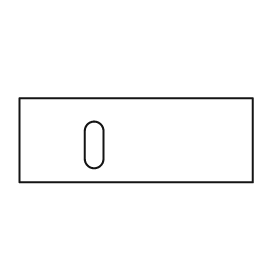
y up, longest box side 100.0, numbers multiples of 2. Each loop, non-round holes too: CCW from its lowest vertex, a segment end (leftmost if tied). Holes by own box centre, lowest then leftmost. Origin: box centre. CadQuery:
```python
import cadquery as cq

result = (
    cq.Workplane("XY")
    .moveTo(-50.0, -18.0)
    .lineTo(50.0, -18.0)
    .lineTo(50.0, 18.0)
    .lineTo(-50.0, 18.0)
    .close()
    .moveTo(-22.0, -8.0)
    .threePointArc((-18.0, -12.0), (-14.0, -8.0))
    .lineTo(-14.0, 4.0)
    .threePointArc((-18.0, 8.0), (-22.0, 4.0))
    .close()
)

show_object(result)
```